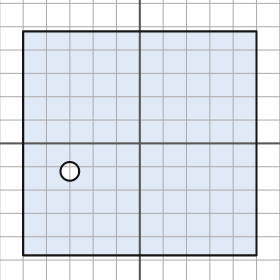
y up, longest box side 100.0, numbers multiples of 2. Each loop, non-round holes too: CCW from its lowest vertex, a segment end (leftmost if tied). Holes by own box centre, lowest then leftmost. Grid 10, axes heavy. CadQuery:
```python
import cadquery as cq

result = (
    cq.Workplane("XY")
    .moveTo(-50.0, -48.0)
    .lineTo(50.0, -48.0)
    .lineTo(50.0, 48.0)
    .lineTo(-50.0, 48.0)
    .close()
    .moveTo(-30.0, -12.0)
    .circle(4.0)
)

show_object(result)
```